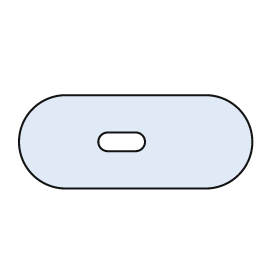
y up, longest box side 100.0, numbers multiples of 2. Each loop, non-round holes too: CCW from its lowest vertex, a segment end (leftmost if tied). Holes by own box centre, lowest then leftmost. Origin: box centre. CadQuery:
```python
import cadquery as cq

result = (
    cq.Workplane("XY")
    .moveTo(-30.0, -20.0)
    .lineTo(30.0, -20.0)
    .threePointArc((50.0, 0.0), (30.0, 20.0))
    .lineTo(-30.0, 20.0)
    .threePointArc((-50.0, 0.0), (-30.0, -20.0))
    .close()
    .moveTo(-12.0, -4.0)
    .lineTo(0.0, -4.0)
    .threePointArc((4.0, 0.0), (0.0, 4.0))
    .lineTo(-12.0, 4.0)
    .threePointArc((-16.0, 0.0), (-12.0, -4.0))
    .close()
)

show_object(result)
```